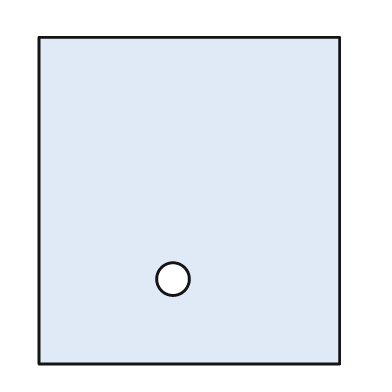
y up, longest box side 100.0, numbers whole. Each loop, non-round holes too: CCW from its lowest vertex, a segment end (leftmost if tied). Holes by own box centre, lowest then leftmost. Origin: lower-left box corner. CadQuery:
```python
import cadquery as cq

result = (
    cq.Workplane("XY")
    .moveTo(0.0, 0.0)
    .lineTo(92.0, 0.0)
    .lineTo(92.0, 100.0)
    .lineTo(0.0, 100.0)
    .close()
    .moveTo(41.0, 26.0)
    .circle(5.0)
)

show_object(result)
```